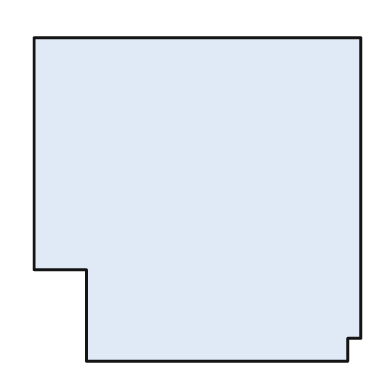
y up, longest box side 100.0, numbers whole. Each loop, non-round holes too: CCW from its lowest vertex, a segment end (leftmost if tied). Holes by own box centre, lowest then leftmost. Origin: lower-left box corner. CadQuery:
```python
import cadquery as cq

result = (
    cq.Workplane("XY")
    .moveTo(16.0, 0.0)
    .lineTo(96.0, 0.0)
    .lineTo(96.0, 7.0)
    .lineTo(100.0, 7.0)
    .lineTo(100.0, 99.0)
    .lineTo(0.0, 99.0)
    .lineTo(0.0, 28.0)
    .lineTo(16.0, 28.0)
    .close()
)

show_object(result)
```